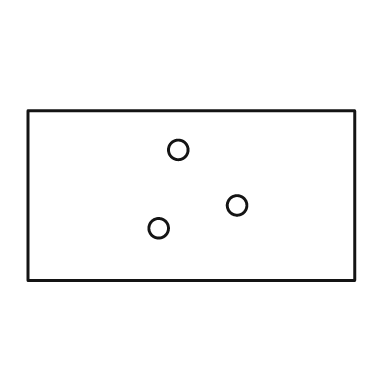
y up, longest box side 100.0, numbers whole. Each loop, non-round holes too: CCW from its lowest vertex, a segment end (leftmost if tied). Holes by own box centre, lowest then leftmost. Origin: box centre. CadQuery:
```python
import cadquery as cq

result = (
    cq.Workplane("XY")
    .moveTo(-50.0, -26.0)
    .lineTo(50.0, -26.0)
    .lineTo(50.0, 26.0)
    .lineTo(-50.0, 26.0)
    .close()
    .moveTo(-10.0, -10.0)
    .circle(3.0)
    .moveTo(14.0, -3.0)
    .circle(3.0)
    .moveTo(-4.0, 14.0)
    .circle(3.0)
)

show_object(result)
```